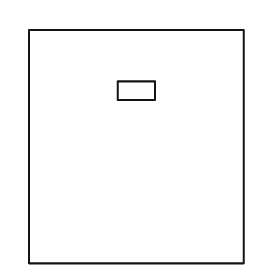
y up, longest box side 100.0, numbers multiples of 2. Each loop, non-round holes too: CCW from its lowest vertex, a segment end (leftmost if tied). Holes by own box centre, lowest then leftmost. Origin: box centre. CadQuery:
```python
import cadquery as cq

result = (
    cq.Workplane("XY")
    .moveTo(-46.0, -50.0)
    .lineTo(46.0, -50.0)
    .lineTo(46.0, 50.0)
    .lineTo(-46.0, 50.0)
    .close()
    .moveTo(-8.0, 20.0)
    .lineTo(8.0, 20.0)
    .lineTo(8.0, 28.0)
    .lineTo(-8.0, 28.0)
    .close()
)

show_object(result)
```